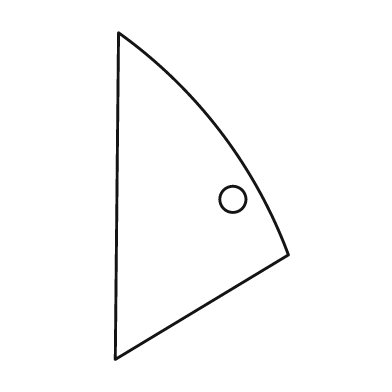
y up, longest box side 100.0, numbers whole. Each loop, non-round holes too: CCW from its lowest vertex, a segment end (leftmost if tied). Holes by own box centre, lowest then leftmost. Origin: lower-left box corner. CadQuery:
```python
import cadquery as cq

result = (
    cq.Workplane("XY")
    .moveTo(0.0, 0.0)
    .lineTo(53.0, 32.0)
    .threePointArc((32.0, 70.0), (1.0, 100.0))
    .close()
    .moveTo(36.0, 49.0)
    .circle(4.0)
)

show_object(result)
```